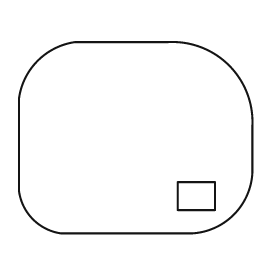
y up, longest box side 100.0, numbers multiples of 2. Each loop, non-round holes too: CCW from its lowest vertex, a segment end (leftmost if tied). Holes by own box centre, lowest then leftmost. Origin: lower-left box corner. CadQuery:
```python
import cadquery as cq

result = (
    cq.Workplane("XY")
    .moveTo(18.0, 0.0)
    .lineTo(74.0, 0.0)
    .threePointArc((92.0, 8.0), (100.0, 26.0))
    .lineTo(100.0, 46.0)
    .threePointArc((90.0, 72.0), (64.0, 82.0))
    .lineTo(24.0, 82.0)
    .threePointArc((8.0, 74.0), (0.0, 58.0))
    .lineTo(0.0, 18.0)
    .threePointArc((6.0, 6.0), (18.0, 0.0))
    .close()
    .moveTo(68.0, 10.0)
    .lineTo(84.0, 10.0)
    .lineTo(84.0, 22.0)
    .lineTo(68.0, 22.0)
    .close()
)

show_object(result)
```